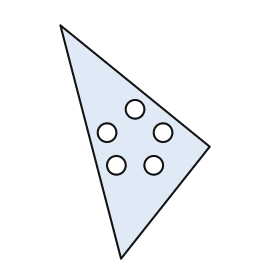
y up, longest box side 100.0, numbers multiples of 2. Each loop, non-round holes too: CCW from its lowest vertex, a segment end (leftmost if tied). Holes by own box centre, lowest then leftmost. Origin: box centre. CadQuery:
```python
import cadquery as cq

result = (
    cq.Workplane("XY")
    .moveTo(-6.0, -50.0)
    .lineTo(32.0, -2.0)
    .lineTo(-32.0, 50.0)
    .close()
    .moveTo(-8.0, -10.0)
    .circle(4.0)
    .moveTo(8.0, -10.0)
    .circle(4.0)
    .moveTo(-12.0, 4.0)
    .circle(4.0)
    .moveTo(12.0, 4.0)
    .circle(4.0)
    .moveTo(0.0, 14.0)
    .circle(4.0)
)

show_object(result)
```